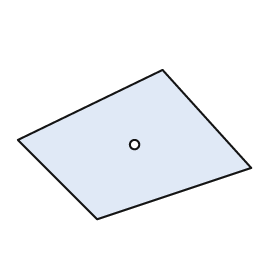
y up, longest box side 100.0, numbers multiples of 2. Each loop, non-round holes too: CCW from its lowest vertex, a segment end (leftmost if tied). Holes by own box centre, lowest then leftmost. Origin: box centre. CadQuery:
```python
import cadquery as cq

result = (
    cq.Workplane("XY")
    .moveTo(-16.0, -32.0)
    .lineTo(50.0, -10.0)
    .lineTo(12.0, 32.0)
    .lineTo(-50.0, 2.0)
    .close()
    .moveTo(0.0, 0.0)
    .circle(2.0)
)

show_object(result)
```